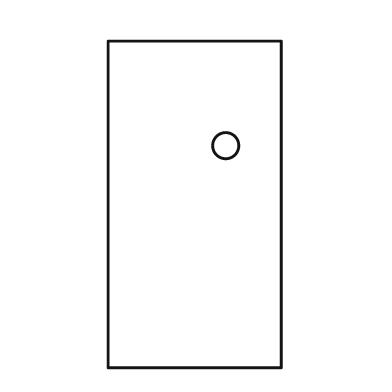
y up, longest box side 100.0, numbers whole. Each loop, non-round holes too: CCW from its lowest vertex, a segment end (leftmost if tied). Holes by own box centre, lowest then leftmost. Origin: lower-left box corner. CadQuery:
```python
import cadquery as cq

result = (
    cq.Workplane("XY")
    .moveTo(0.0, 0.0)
    .lineTo(53.0, 0.0)
    .lineTo(53.0, 100.0)
    .lineTo(0.0, 100.0)
    .close()
    .moveTo(36.0, 68.0)
    .circle(4.0)
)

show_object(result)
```